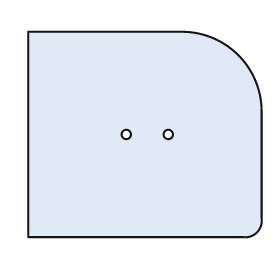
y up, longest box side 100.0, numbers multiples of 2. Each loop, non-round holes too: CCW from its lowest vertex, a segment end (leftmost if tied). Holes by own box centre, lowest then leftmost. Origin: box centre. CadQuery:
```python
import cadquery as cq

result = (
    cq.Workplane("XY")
    .moveTo(-50.0, -44.0)
    .lineTo(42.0, -44.0)
    .threePointArc((48.0, -42.0), (50.0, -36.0))
    .lineTo(50.0, 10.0)
    .threePointArc((40.0, 34.0), (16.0, 44.0))
    .lineTo(-50.0, 44.0)
    .close()
    .moveTo(-8.0, 0.0)
    .circle(2.0)
    .moveTo(10.0, 0.0)
    .circle(2.0)
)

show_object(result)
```